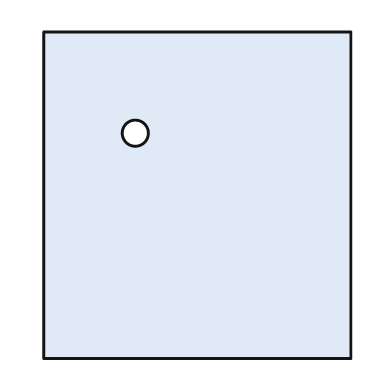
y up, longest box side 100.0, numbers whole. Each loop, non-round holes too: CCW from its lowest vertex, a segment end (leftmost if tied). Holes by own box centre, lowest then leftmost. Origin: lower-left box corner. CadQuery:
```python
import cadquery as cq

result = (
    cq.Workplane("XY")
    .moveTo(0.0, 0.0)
    .lineTo(94.0, 0.0)
    .lineTo(94.0, 100.0)
    .lineTo(0.0, 100.0)
    .close()
    .moveTo(28.0, 69.0)
    .circle(4.0)
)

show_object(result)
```